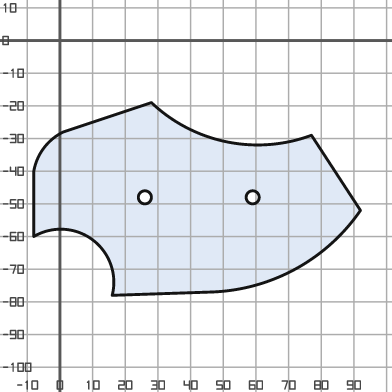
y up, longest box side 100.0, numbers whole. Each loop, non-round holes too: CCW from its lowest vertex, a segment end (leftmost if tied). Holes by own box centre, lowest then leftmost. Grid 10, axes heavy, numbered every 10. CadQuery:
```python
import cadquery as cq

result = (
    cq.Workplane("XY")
    .moveTo(16.0, -78.0)
    .lineTo(46.0, -77.0)
    .threePointArc((72.0, -70.0), (92.0, -52.0))
    .lineTo(77.0, -29.0)
    .threePointArc((51.0, -31.0), (28.0, -19.0))
    .lineTo(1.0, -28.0)
    .threePointArc((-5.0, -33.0), (-8.0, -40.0))
    .lineTo(-8.0, -60.0)
    .threePointArc((10.0, -61.0), (16.0, -78.0))
    .close()
    .moveTo(26.0, -48.0)
    .circle(2.0)
    .moveTo(59.0, -48.0)
    .circle(2.0)
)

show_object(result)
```